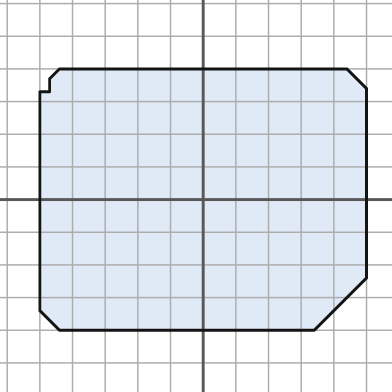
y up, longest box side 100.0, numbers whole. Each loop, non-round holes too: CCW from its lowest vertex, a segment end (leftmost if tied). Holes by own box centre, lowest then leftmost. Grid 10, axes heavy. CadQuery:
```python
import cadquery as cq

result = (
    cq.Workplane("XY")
    .moveTo(-44.0, -40.0)
    .lineTo(34.0, -40.0)
    .lineTo(50.0, -24.0)
    .lineTo(50.0, 34.0)
    .lineTo(44.0, 40.0)
    .lineTo(-44.0, 40.0)
    .lineTo(-47.0, 37.0)
    .lineTo(-47.0, 33.0)
    .lineTo(-50.0, 33.0)
    .lineTo(-50.0, -34.0)
    .close()
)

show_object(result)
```